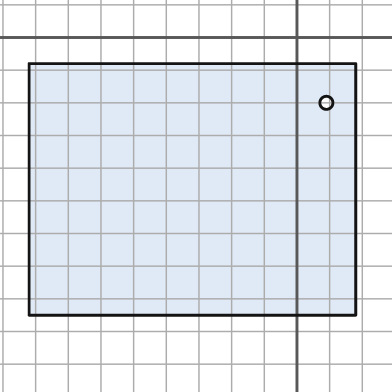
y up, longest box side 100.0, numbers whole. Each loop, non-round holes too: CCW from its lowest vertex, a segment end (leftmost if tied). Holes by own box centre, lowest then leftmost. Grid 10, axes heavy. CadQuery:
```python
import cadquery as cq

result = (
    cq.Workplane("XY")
    .moveTo(-82.0, -85.0)
    .lineTo(18.0, -85.0)
    .lineTo(18.0, -8.0)
    .lineTo(-82.0, -8.0)
    .close()
    .moveTo(9.0, -20.0)
    .circle(2.0)
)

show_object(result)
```